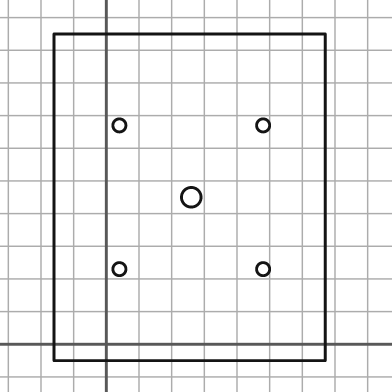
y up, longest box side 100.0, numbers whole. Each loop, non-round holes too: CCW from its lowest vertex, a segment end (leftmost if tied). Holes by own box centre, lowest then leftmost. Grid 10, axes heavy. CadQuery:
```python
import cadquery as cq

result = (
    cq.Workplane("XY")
    .moveTo(-16.0, -5.0)
    .lineTo(67.0, -5.0)
    .lineTo(67.0, 95.0)
    .lineTo(-16.0, 95.0)
    .close()
    .moveTo(4.0, 23.0)
    .circle(2.0)
    .moveTo(48.0, 23.0)
    .circle(2.0)
    .moveTo(26.0, 45.0)
    .circle(3.0)
    .moveTo(4.0, 67.0)
    .circle(2.0)
    .moveTo(48.0, 67.0)
    .circle(2.0)
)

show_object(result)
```